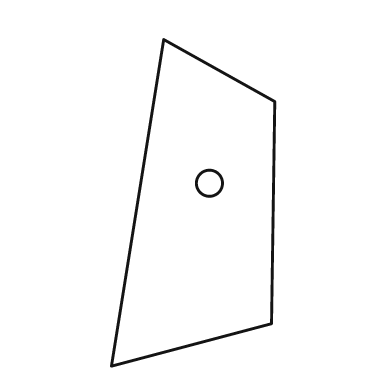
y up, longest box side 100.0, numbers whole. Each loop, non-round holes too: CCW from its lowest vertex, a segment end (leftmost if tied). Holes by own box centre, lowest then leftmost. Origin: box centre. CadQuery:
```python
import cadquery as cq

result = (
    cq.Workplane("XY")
    .moveTo(-25.0, -50.0)
    .lineTo(24.0, -37.0)
    .lineTo(25.0, 31.0)
    .lineTo(-9.0, 50.0)
    .close()
    .moveTo(5.0, 6.0)
    .circle(4.0)
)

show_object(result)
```